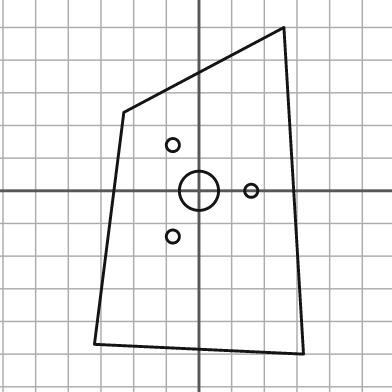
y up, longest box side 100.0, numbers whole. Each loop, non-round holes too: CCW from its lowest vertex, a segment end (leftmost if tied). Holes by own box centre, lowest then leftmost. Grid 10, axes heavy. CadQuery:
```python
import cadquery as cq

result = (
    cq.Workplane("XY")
    .moveTo(32.0, -50.0)
    .lineTo(26.0, 50.0)
    .lineTo(-23.0, 24.0)
    .lineTo(-32.0, -47.0)
    .close()
    .moveTo(-8.0, -14.0)
    .circle(2.0)
    .moveTo(0.0, 0.0)
    .circle(6.0)
    .moveTo(16.0, 0.0)
    .circle(2.0)
    .moveTo(-8.0, 14.0)
    .circle(2.0)
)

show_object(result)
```